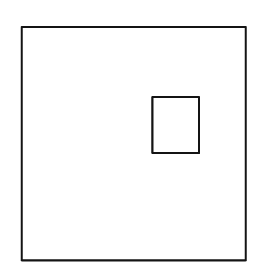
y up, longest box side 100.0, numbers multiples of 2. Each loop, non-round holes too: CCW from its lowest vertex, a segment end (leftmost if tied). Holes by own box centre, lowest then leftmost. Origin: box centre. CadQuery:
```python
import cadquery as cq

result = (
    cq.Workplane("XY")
    .moveTo(-48.0, -50.0)
    .lineTo(48.0, -50.0)
    .lineTo(48.0, 50.0)
    .lineTo(-48.0, 50.0)
    .close()
    .moveTo(8.0, -4.0)
    .lineTo(28.0, -4.0)
    .lineTo(28.0, 20.0)
    .lineTo(8.0, 20.0)
    .close()
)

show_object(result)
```